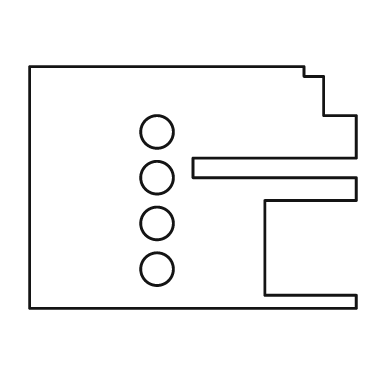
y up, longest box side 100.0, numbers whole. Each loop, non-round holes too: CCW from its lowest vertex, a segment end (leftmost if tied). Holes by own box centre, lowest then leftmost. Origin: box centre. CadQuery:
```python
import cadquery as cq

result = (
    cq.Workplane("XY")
    .moveTo(-50.0, -37.0)
    .lineTo(50.0, -37.0)
    .lineTo(50.0, -33.0)
    .lineTo(22.0, -33.0)
    .lineTo(22.0, -4.0)
    .lineTo(50.0, -4.0)
    .lineTo(50.0, 3.0)
    .lineTo(0.0, 3.0)
    .lineTo(0.0, 9.0)
    .lineTo(50.0, 9.0)
    .lineTo(50.0, 22.0)
    .lineTo(40.0, 22.0)
    .lineTo(40.0, 34.0)
    .lineTo(34.0, 34.0)
    .lineTo(34.0, 37.0)
    .lineTo(-50.0, 37.0)
    .close()
    .moveTo(-11.0, -25.0)
    .circle(5.0)
    .moveTo(-11.0, -11.0)
    .circle(5.0)
    .moveTo(-11.0, 3.0)
    .circle(5.0)
    .moveTo(-11.0, 17.0)
    .circle(5.0)
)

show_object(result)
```